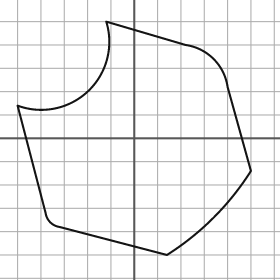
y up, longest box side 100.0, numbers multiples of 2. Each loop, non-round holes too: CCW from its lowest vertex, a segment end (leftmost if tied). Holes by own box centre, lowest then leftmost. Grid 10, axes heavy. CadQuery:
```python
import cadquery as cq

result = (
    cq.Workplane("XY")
    .moveTo(14.0, -50.0)
    .threePointArc((34.0, -34.0), (50.0, -14.0))
    .lineTo(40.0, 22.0)
    .threePointArc((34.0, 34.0), (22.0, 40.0))
    .lineTo(-12.0, 50.0)
    .threePointArc((-20.0, 20.0), (-50.0, 14.0))
    .lineTo(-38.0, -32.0)
    .threePointArc((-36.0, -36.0), (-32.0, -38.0))
    .close()
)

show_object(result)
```